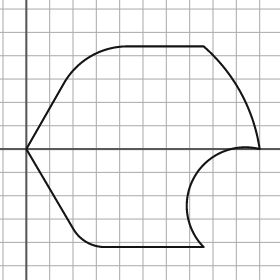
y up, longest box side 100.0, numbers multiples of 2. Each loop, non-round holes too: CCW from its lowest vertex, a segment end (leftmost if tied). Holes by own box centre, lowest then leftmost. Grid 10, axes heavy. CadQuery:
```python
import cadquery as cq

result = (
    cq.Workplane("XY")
    .moveTo(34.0, -42.0)
    .lineTo(76.0, -42.0)
    .threePointArc((72.0, -12.0), (100.0, 0.0))
    .threePointArc((92.0, 24.0), (76.0, 44.0))
    .lineTo(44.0, 44.0)
    .threePointArc((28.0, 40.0), (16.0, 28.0))
    .lineTo(0.0, 0.0)
    .lineTo(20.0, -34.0)
    .threePointArc((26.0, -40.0), (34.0, -42.0))
    .close()
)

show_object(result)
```